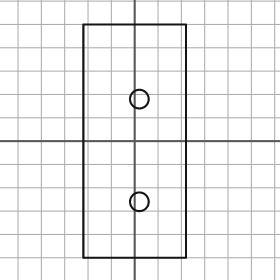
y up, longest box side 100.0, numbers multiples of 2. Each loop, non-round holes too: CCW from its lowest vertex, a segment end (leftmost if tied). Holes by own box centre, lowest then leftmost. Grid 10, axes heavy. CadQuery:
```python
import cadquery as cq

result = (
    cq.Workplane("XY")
    .moveTo(-22.0, -50.0)
    .lineTo(22.0, -50.0)
    .lineTo(22.0, 50.0)
    .lineTo(-22.0, 50.0)
    .close()
    .moveTo(2.0, -26.0)
    .circle(4.0)
    .moveTo(2.0, 18.0)
    .circle(4.0)
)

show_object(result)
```